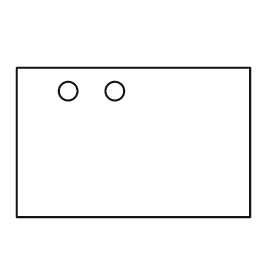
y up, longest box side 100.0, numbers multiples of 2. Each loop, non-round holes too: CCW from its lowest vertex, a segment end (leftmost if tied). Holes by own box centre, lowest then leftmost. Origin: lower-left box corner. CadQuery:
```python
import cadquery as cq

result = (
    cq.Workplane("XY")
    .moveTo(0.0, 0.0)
    .lineTo(100.0, 0.0)
    .lineTo(100.0, 64.0)
    .lineTo(0.0, 64.0)
    .close()
    .moveTo(22.0, 54.0)
    .circle(4.0)
    .moveTo(42.0, 54.0)
    .circle(4.0)
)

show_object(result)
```